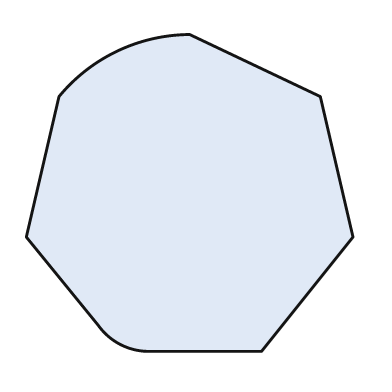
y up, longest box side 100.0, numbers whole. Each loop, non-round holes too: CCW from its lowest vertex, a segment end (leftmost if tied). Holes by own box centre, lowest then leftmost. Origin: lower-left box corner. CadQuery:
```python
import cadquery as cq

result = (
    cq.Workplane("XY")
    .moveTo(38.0, 0.0)
    .lineTo(72.0, 0.0)
    .lineTo(100.0, 35.0)
    .lineTo(90.0, 78.0)
    .lineTo(50.0, 97.0)
    .threePointArc((28.0, 92.0), (10.0, 78.0))
    .lineTo(0.0, 35.0)
    .lineTo(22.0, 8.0)
    .threePointArc((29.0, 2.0), (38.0, 0.0))
    .close()
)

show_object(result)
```